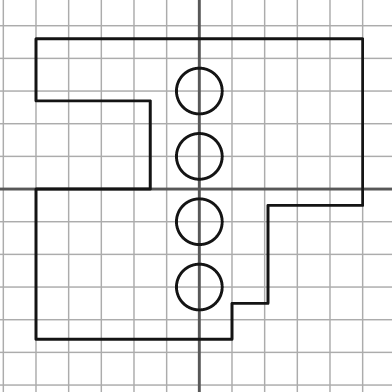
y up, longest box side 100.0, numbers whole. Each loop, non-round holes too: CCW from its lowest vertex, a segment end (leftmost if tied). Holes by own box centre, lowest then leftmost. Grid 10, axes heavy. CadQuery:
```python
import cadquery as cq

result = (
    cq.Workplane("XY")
    .moveTo(-50.0, -46.0)
    .lineTo(10.0, -46.0)
    .lineTo(10.0, -35.0)
    .lineTo(21.0, -35.0)
    .lineTo(21.0, -5.0)
    .lineTo(50.0, -5.0)
    .lineTo(50.0, 46.0)
    .lineTo(-50.0, 46.0)
    .lineTo(-50.0, 27.0)
    .lineTo(-15.0, 27.0)
    .lineTo(-15.0, 0.0)
    .lineTo(-50.0, 0.0)
    .close()
    .moveTo(0.0, -30.0)
    .circle(7.0)
    .moveTo(0.0, -10.0)
    .circle(7.0)
    .moveTo(0.0, 10.0)
    .circle(7.0)
    .moveTo(0.0, 30.0)
    .circle(7.0)
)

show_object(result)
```